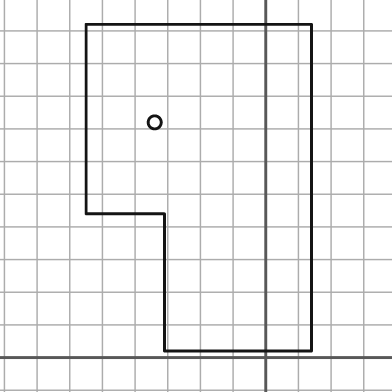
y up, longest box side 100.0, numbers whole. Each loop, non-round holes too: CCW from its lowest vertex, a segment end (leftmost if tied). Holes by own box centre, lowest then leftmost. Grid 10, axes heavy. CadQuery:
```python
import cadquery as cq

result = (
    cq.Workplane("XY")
    .moveTo(-31.0, 2.0)
    .lineTo(14.0, 2.0)
    .lineTo(14.0, 102.0)
    .lineTo(-55.0, 102.0)
    .lineTo(-55.0, 44.0)
    .lineTo(-31.0, 44.0)
    .close()
    .moveTo(-34.0, 72.0)
    .circle(2.0)
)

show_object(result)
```